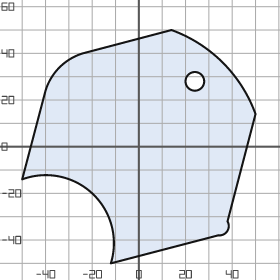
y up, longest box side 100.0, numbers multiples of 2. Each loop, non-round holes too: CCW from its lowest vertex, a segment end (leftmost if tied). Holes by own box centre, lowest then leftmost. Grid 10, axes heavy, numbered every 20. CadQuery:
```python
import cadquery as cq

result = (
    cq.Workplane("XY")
    .moveTo(-12.0, -50.0)
    .lineTo(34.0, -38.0)
    .threePointArc((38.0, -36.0), (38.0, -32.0))
    .lineTo(50.0, 14.0)
    .threePointArc((36.0, 36.0), (14.0, 50.0))
    .lineTo(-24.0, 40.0)
    .threePointArc((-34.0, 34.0), (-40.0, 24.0))
    .lineTo(-50.0, -14.0)
    .threePointArc((-20.0, -20.0), (-12.0, -50.0))
    .close()
    .moveTo(24.0, 28.0)
    .circle(4.0)
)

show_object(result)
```